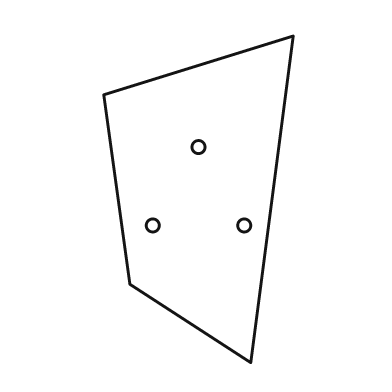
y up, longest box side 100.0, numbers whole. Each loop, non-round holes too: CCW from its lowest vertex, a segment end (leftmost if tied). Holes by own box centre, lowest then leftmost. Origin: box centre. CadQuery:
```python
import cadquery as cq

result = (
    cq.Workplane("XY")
    .moveTo(16.0, -50.0)
    .lineTo(29.0, 50.0)
    .lineTo(-29.0, 32.0)
    .lineTo(-21.0, -26.0)
    .close()
    .moveTo(-14.0, -8.0)
    .circle(2.0)
    .moveTo(14.0, -8.0)
    .circle(2.0)
    .moveTo(0.0, 16.0)
    .circle(2.0)
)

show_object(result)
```